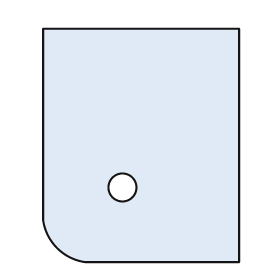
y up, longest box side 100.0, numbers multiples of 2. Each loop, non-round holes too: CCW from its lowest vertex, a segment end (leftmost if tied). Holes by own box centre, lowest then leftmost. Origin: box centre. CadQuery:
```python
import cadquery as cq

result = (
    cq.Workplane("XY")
    .moveTo(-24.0, -50.0)
    .lineTo(42.0, -50.0)
    .lineTo(42.0, 50.0)
    .lineTo(-42.0, 50.0)
    .lineTo(-42.0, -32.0)
    .threePointArc((-36.0, -44.0), (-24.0, -50.0))
    .close()
    .moveTo(-8.0, -18.0)
    .circle(6.0)
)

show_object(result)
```